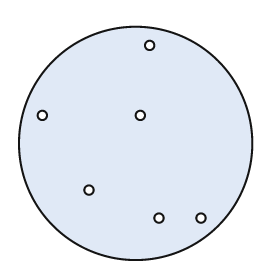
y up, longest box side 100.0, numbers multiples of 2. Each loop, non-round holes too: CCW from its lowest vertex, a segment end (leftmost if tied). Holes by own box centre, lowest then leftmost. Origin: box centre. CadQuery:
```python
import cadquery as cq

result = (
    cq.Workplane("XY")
    .moveTo(0.0, 0.0)
    .circle(50.0)
    .moveTo(10.0, -32.0)
    .circle(2.0)
    .moveTo(28.0, -32.0)
    .circle(2.0)
    .moveTo(-20.0, -20.0)
    .circle(2.0)
    .moveTo(-40.0, 12.0)
    .circle(2.0)
    .moveTo(2.0, 12.0)
    .circle(2.0)
    .moveTo(6.0, 42.0)
    .circle(2.0)
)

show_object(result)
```